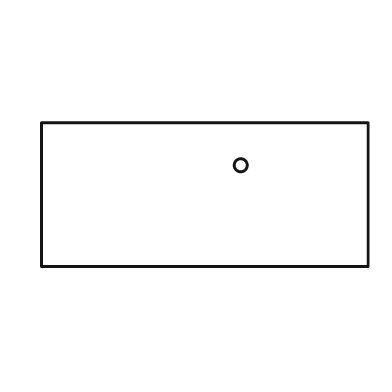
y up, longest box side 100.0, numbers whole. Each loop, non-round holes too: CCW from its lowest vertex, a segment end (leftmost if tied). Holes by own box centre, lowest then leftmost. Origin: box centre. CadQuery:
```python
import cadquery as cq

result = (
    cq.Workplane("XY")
    .moveTo(-50.0, -22.0)
    .lineTo(50.0, -22.0)
    .lineTo(50.0, 22.0)
    .lineTo(-50.0, 22.0)
    .close()
    .moveTo(11.0, 9.0)
    .circle(2.0)
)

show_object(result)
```